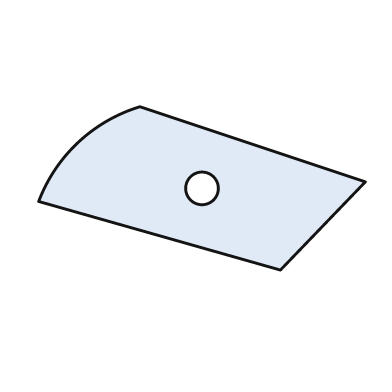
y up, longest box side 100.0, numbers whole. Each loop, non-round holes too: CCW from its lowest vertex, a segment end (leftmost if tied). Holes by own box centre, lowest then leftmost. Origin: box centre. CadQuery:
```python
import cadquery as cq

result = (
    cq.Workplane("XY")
    .moveTo(24.0, -25.0)
    .lineTo(50.0, 2.0)
    .lineTo(-19.0, 25.0)
    .threePointArc((-38.0, 14.0), (-50.0, -4.0))
    .close()
    .moveTo(0.0, 0.0)
    .circle(5.0)
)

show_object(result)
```